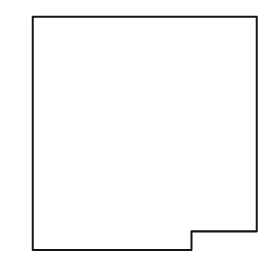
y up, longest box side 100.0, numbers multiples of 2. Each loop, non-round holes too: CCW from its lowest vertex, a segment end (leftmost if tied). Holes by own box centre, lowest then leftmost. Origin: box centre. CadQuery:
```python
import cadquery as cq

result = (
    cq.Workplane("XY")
    .moveTo(-48.0, -50.0)
    .lineTo(20.0, -50.0)
    .lineTo(20.0, -42.0)
    .lineTo(48.0, -42.0)
    .lineTo(48.0, 50.0)
    .lineTo(-48.0, 50.0)
    .close()
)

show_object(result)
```